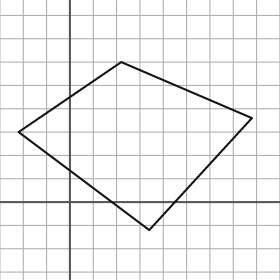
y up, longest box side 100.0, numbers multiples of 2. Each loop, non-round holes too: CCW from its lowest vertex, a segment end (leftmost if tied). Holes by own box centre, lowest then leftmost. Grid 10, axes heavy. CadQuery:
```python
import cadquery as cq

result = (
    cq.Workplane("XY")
    .moveTo(34.0, -12.0)
    .lineTo(78.0, 36.0)
    .lineTo(22.0, 60.0)
    .lineTo(-22.0, 30.0)
    .close()
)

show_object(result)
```